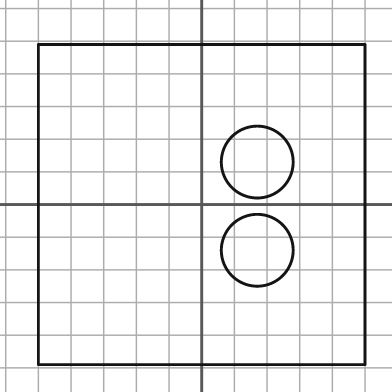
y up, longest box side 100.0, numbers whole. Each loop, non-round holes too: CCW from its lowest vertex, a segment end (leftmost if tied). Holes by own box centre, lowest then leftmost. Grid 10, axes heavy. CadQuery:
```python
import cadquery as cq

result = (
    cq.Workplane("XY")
    .moveTo(-50.0, -49.0)
    .lineTo(50.0, -49.0)
    .lineTo(50.0, 49.0)
    .lineTo(-50.0, 49.0)
    .close()
    .moveTo(17.0, -14.0)
    .circle(11.0)
    .moveTo(17.0, 13.0)
    .circle(11.0)
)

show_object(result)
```